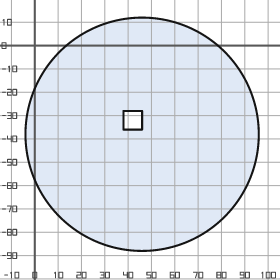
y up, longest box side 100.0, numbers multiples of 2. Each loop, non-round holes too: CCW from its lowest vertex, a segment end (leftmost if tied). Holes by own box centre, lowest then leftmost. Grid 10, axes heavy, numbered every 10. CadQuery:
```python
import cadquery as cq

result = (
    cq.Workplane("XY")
    .moveTo(46.0, -38.0)
    .circle(50.0)
    .moveTo(38.0, -36.0)
    .lineTo(46.0, -36.0)
    .lineTo(46.0, -28.0)
    .lineTo(38.0, -28.0)
    .close()
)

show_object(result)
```